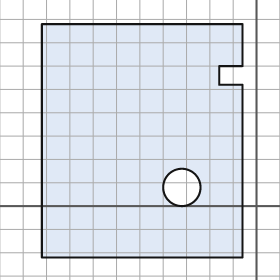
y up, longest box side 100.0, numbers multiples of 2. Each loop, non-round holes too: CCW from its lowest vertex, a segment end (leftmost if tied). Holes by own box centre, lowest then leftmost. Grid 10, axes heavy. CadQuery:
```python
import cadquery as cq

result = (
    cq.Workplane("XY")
    .moveTo(-92.0, -22.0)
    .lineTo(-6.0, -22.0)
    .lineTo(-6.0, 52.0)
    .lineTo(-16.0, 52.0)
    .lineTo(-16.0, 60.0)
    .lineTo(-6.0, 60.0)
    .lineTo(-6.0, 78.0)
    .lineTo(-92.0, 78.0)
    .close()
    .moveTo(-32.0, 8.0)
    .circle(8.0)
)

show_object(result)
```